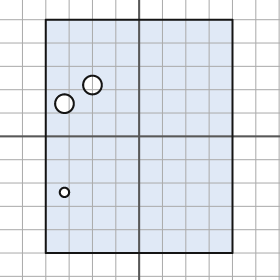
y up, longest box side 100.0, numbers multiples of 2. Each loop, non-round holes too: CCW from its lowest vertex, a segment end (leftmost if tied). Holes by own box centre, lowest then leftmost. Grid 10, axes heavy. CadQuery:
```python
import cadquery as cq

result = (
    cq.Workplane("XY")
    .moveTo(-40.0, -50.0)
    .lineTo(40.0, -50.0)
    .lineTo(40.0, 50.0)
    .lineTo(-40.0, 50.0)
    .close()
    .moveTo(-32.0, -24.0)
    .circle(2.0)
    .moveTo(-32.0, 14.0)
    .circle(4.0)
    .moveTo(-20.0, 22.0)
    .circle(4.0)
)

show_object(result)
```